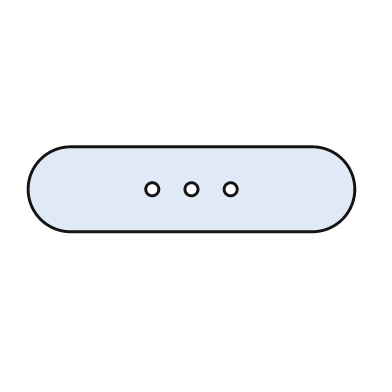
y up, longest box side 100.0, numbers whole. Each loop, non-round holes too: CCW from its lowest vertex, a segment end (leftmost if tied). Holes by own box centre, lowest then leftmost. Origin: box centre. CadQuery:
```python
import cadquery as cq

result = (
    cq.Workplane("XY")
    .moveTo(-37.0, -13.0)
    .lineTo(37.0, -13.0)
    .threePointArc((50.0, 0.0), (37.0, 13.0))
    .lineTo(-37.0, 13.0)
    .threePointArc((-50.0, 0.0), (-37.0, -13.0))
    .close()
    .moveTo(-12.0, 0.0)
    .circle(2.0)
    .moveTo(0.0, 0.0)
    .circle(2.0)
    .moveTo(12.0, 0.0)
    .circle(2.0)
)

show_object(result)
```